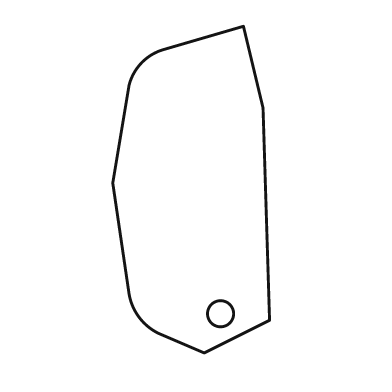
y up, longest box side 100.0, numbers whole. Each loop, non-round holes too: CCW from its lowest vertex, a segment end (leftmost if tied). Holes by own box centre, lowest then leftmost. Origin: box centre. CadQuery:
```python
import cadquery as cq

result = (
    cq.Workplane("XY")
    .moveTo(4.0, -50.0)
    .lineTo(24.0, -40.0)
    .lineTo(22.0, 25.0)
    .lineTo(16.0, 50.0)
    .lineTo(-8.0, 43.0)
    .threePointArc((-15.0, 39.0), (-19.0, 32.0))
    .lineTo(-24.0, 2.0)
    .lineTo(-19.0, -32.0)
    .threePointArc((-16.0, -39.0), (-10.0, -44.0))
    .close()
    .moveTo(9.0, -38.0)
    .circle(4.0)
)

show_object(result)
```